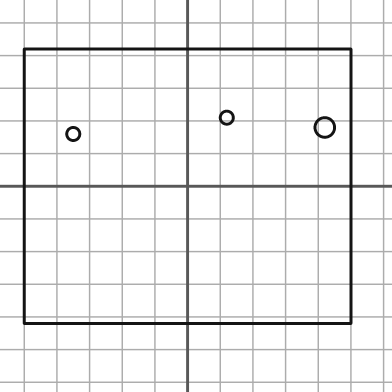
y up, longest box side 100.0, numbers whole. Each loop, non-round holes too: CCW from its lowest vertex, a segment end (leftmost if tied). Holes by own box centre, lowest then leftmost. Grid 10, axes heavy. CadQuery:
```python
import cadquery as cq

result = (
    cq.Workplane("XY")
    .moveTo(-50.0, -42.0)
    .lineTo(50.0, -42.0)
    .lineTo(50.0, 42.0)
    .lineTo(-50.0, 42.0)
    .close()
    .moveTo(-35.0, 16.0)
    .circle(2.0)
    .moveTo(42.0, 18.0)
    .circle(3.0)
    .moveTo(12.0, 21.0)
    .circle(2.0)
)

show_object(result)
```